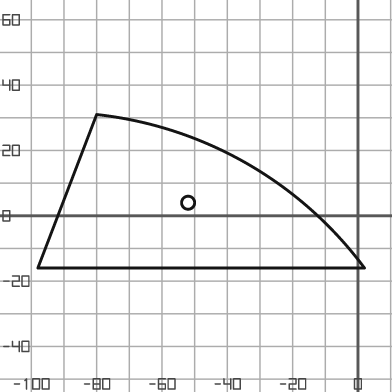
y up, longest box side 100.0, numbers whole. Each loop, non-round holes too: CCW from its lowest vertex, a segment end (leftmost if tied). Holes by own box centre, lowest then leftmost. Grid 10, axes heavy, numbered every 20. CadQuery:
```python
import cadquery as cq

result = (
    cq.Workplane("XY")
    .moveTo(-98.0, -16.0)
    .lineTo(2.0, -16.0)
    .threePointArc((-34.0, 16.0), (-80.0, 31.0))
    .close()
    .moveTo(-52.0, 4.0)
    .circle(2.0)
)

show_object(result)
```